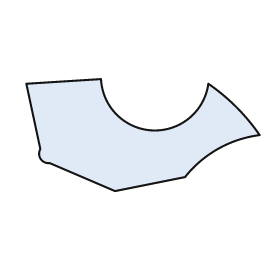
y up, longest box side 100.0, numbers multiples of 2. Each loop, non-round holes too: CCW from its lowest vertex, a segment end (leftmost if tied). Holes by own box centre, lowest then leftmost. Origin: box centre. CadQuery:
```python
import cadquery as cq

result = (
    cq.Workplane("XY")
    .moveTo(-12.0, -24.0)
    .lineTo(18.0, -18.0)
    .threePointArc((32.0, -6.0), (50.0, 0.0))
    .threePointArc((40.0, 12.0), (28.0, 22.0))
    .threePointArc((4.0, 2.0), (-18.0, 24.0))
    .lineTo(-50.0, 22.0)
    .lineTo(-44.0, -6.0)
    .threePointArc((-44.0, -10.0), (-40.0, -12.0))
    .close()
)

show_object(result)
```